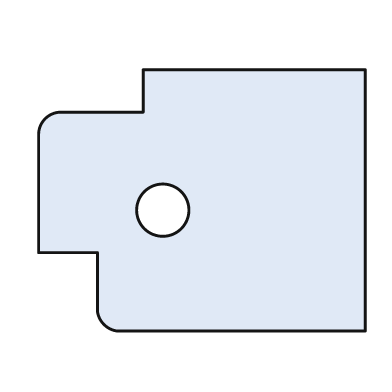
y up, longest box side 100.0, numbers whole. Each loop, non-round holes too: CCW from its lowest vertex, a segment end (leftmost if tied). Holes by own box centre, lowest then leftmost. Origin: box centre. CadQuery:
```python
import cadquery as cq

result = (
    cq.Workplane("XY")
    .moveTo(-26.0, -40.0)
    .lineTo(50.0, -40.0)
    .lineTo(50.0, 40.0)
    .lineTo(-18.0, 40.0)
    .lineTo(-18.0, 27.0)
    .lineTo(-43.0, 27.0)
    .threePointArc((-48.0, 25.0), (-50.0, 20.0))
    .lineTo(-50.0, -16.0)
    .lineTo(-32.0, -16.0)
    .lineTo(-32.0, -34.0)
    .threePointArc((-30.0, -38.0), (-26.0, -40.0))
    .close()
    .moveTo(-12.0, -3.0)
    .circle(8.0)
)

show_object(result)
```